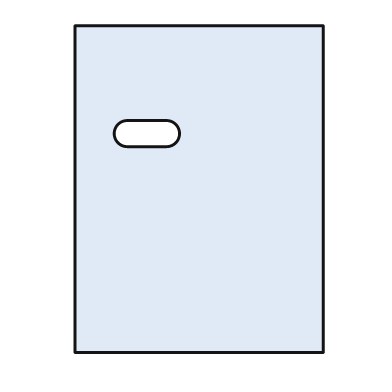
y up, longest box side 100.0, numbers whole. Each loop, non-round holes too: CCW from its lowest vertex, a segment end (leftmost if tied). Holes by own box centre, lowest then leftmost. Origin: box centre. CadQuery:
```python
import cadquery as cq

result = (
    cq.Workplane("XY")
    .moveTo(-38.0, -50.0)
    .lineTo(38.0, -50.0)
    .lineTo(38.0, 50.0)
    .lineTo(-38.0, 50.0)
    .close()
    .moveTo(-22.0, 13.0)
    .lineTo(-10.0, 13.0)
    .threePointArc((-6.0, 17.0), (-10.0, 21.0))
    .lineTo(-22.0, 21.0)
    .threePointArc((-26.0, 17.0), (-22.0, 13.0))
    .close()
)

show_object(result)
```